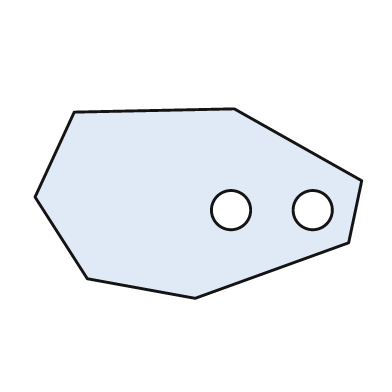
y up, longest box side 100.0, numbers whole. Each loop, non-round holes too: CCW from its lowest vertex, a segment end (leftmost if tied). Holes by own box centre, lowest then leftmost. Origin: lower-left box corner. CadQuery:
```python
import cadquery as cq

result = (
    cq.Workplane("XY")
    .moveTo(49.0, 0.0)
    .lineTo(96.0, 17.0)
    .lineTo(100.0, 36.0)
    .lineTo(61.0, 58.0)
    .lineTo(12.0, 57.0)
    .lineTo(0.0, 31.0)
    .lineTo(16.0, 6.0)
    .close()
    .moveTo(60.0, 27.0)
    .circle(6.0)
    .moveTo(85.0, 27.0)
    .circle(6.0)
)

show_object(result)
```